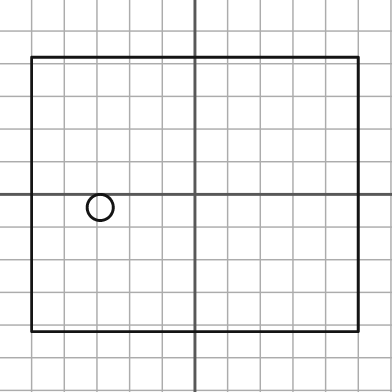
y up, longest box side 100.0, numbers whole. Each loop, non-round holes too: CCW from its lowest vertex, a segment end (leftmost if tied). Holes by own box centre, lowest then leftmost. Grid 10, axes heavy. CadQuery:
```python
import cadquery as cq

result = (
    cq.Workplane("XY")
    .moveTo(-50.0, -42.0)
    .lineTo(50.0, -42.0)
    .lineTo(50.0, 42.0)
    .lineTo(-50.0, 42.0)
    .close()
    .moveTo(-29.0, -4.0)
    .circle(4.0)
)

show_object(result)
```